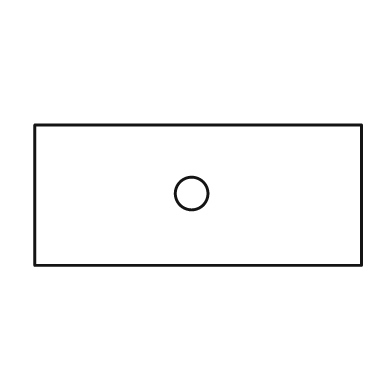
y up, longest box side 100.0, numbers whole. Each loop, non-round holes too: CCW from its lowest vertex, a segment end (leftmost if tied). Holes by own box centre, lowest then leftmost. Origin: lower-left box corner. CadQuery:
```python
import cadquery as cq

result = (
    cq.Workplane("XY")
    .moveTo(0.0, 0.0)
    .lineTo(100.0, 0.0)
    .lineTo(100.0, 43.0)
    .lineTo(0.0, 43.0)
    .close()
    .moveTo(48.0, 22.0)
    .circle(5.0)
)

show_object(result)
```